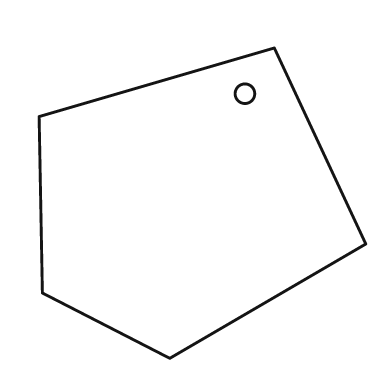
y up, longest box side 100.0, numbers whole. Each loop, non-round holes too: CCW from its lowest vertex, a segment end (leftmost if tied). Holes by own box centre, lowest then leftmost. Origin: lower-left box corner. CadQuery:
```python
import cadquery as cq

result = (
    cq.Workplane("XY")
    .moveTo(40.0, 0.0)
    .lineTo(100.0, 35.0)
    .lineTo(72.0, 95.0)
    .lineTo(0.0, 74.0)
    .lineTo(1.0, 20.0)
    .close()
    .moveTo(63.0, 81.0)
    .circle(3.0)
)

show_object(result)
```